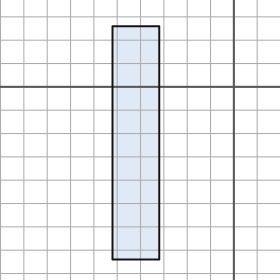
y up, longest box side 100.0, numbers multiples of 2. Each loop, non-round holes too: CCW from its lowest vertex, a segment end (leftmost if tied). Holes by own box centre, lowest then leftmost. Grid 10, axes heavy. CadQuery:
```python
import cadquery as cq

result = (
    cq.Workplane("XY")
    .moveTo(-52.0, -74.0)
    .lineTo(-32.0, -74.0)
    .lineTo(-32.0, 26.0)
    .lineTo(-52.0, 26.0)
    .close()
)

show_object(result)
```